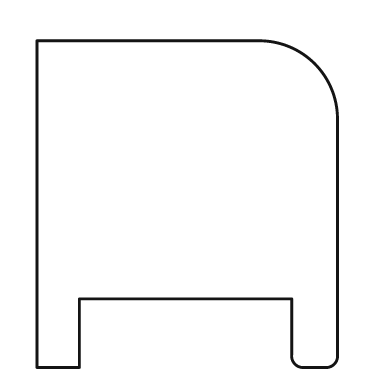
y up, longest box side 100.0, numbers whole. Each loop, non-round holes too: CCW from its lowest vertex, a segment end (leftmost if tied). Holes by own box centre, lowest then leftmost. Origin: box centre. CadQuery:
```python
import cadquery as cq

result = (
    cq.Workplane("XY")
    .moveTo(-46.0, -50.0)
    .lineTo(-33.0, -50.0)
    .lineTo(-33.0, -29.0)
    .lineTo(32.0, -29.0)
    .lineTo(32.0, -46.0)
    .threePointArc((33.0, -49.0), (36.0, -50.0))
    .lineTo(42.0, -50.0)
    .threePointArc((45.0, -49.0), (46.0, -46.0))
    .lineTo(46.0, 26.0)
    .threePointArc((39.0, 43.0), (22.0, 50.0))
    .lineTo(-46.0, 50.0)
    .close()
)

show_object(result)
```